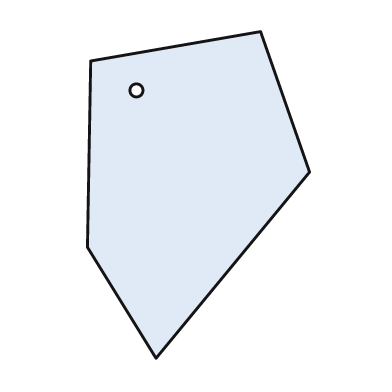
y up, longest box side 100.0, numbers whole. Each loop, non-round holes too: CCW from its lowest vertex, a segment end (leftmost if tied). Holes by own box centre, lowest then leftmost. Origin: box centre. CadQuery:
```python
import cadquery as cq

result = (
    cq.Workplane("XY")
    .moveTo(-13.0, -50.0)
    .lineTo(34.0, 7.0)
    .lineTo(19.0, 50.0)
    .lineTo(-33.0, 41.0)
    .lineTo(-34.0, -16.0)
    .close()
    .moveTo(-19.0, 32.0)
    .circle(2.0)
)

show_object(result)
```